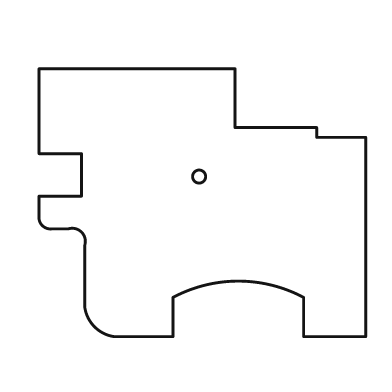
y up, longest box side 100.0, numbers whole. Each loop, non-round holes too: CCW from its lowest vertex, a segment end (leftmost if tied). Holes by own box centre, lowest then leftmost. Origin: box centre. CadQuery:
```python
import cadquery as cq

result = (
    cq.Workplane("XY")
    .moveTo(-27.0, -41.0)
    .lineTo(-9.0, -41.0)
    .lineTo(-9.0, -29.0)
    .threePointArc((11.0, -24.0), (31.0, -29.0))
    .lineTo(31.0, -41.0)
    .lineTo(50.0, -41.0)
    .lineTo(50.0, 20.0)
    .lineTo(35.0, 20.0)
    .lineTo(35.0, 23.0)
    .lineTo(10.0, 23.0)
    .lineTo(10.0, 41.0)
    .lineTo(-50.0, 41.0)
    .lineTo(-50.0, 15.0)
    .lineTo(-37.0, 15.0)
    .lineTo(-37.0, 2.0)
    .lineTo(-50.0, 2.0)
    .lineTo(-50.0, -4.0)
    .threePointArc((-49.0, -7.0), (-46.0, -8.0))
    .lineTo(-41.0, -8.0)
    .threePointArc((-37.0, -9.0), (-36.0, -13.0))
    .lineTo(-36.0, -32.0)
    .threePointArc((-33.0, -38.0), (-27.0, -41.0))
    .close()
    .moveTo(-1.0, 8.0)
    .circle(2.0)
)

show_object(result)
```